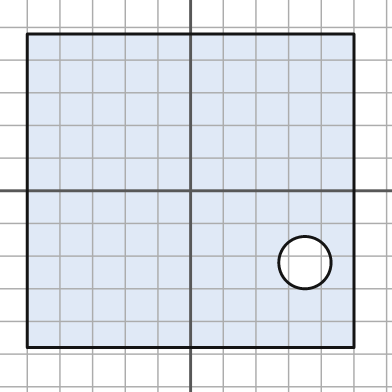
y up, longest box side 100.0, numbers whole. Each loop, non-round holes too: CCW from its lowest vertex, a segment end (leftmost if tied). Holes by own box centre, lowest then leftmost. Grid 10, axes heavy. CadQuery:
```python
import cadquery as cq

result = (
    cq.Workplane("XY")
    .moveTo(-50.0, -48.0)
    .lineTo(50.0, -48.0)
    .lineTo(50.0, 48.0)
    .lineTo(-50.0, 48.0)
    .close()
    .moveTo(35.0, -22.0)
    .circle(8.0)
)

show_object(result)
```